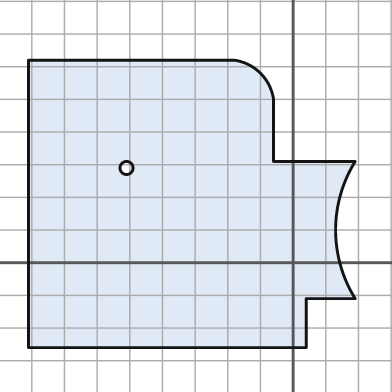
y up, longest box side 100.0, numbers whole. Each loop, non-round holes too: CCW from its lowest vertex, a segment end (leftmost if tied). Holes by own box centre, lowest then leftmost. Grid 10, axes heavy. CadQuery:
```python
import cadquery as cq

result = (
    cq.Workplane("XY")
    .moveTo(-81.0, -26.0)
    .lineTo(4.0, -26.0)
    .lineTo(4.0, -11.0)
    .lineTo(19.0, -11.0)
    .threePointArc((13.0, 10.0), (19.0, 31.0))
    .lineTo(-6.0, 31.0)
    .lineTo(-6.0, 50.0)
    .threePointArc((-10.0, 58.0), (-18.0, 62.0))
    .lineTo(-81.0, 62.0)
    .close()
    .moveTo(-51.0, 29.0)
    .circle(2.0)
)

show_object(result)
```